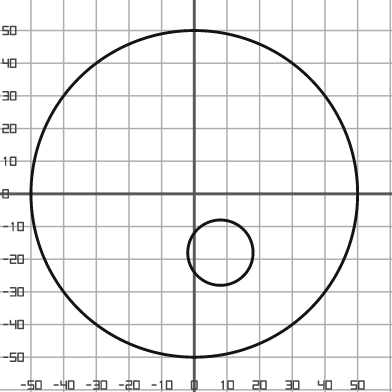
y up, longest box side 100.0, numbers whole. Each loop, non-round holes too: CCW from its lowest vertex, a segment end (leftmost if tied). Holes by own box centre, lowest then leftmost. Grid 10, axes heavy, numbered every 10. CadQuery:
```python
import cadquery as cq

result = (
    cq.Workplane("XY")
    .moveTo(0.0, 0.0)
    .circle(50.0)
    .moveTo(8.0, -18.0)
    .circle(10.0)
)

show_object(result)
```